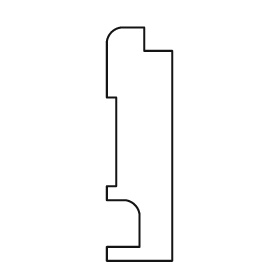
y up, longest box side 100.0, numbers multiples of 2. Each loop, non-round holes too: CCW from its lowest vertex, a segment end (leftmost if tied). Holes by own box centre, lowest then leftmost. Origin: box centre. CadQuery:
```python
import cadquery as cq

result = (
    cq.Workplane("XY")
    .moveTo(-14.0, -50.0)
    .lineTo(14.0, -50.0)
    .lineTo(14.0, 40.0)
    .lineTo(2.0, 40.0)
    .lineTo(2.0, 50.0)
    .lineTo(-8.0, 50.0)
    .threePointArc((-12.0, 48.0), (-14.0, 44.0))
    .lineTo(-14.0, 20.0)
    .lineTo(-10.0, 20.0)
    .lineTo(-10.0, -18.0)
    .lineTo(-14.0, -18.0)
    .lineTo(-14.0, -24.0)
    .lineTo(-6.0, -24.0)
    .threePointArc((-2.0, -26.0), (0.0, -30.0))
    .lineTo(0.0, -44.0)
    .lineTo(-14.0, -44.0)
    .close()
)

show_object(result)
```